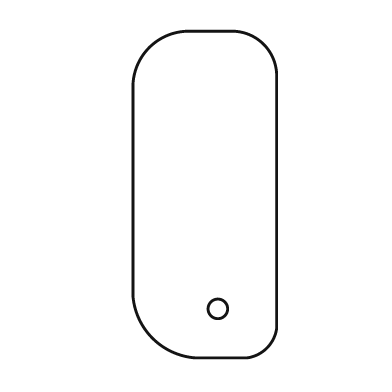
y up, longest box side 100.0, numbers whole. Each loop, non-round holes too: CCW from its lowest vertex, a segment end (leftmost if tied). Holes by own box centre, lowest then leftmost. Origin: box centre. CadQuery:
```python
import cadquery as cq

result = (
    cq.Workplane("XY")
    .moveTo(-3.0, -50.0)
    .lineTo(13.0, -50.0)
    .threePointArc((19.0, -47.0), (22.0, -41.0))
    .lineTo(22.0, 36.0)
    .threePointArc((18.0, 46.0), (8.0, 50.0))
    .lineTo(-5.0, 50.0)
    .threePointArc((-17.0, 45.0), (-22.0, 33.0))
    .lineTo(-22.0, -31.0)
    .threePointArc((-16.0, -44.0), (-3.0, -50.0))
    .close()
    .moveTo(4.0, -35.0)
    .circle(3.0)
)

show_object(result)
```